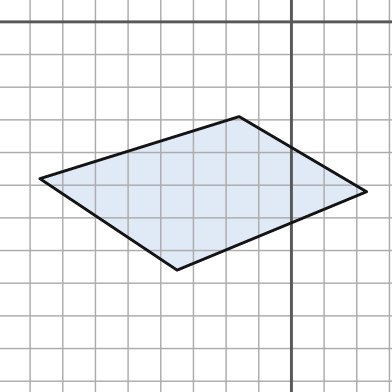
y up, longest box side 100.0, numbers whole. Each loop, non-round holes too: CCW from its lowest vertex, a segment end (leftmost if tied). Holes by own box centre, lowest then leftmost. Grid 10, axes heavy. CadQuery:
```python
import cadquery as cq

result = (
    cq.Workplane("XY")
    .moveTo(-35.0, -76.0)
    .lineTo(23.0, -52.0)
    .lineTo(-16.0, -29.0)
    .lineTo(-77.0, -48.0)
    .close()
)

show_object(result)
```